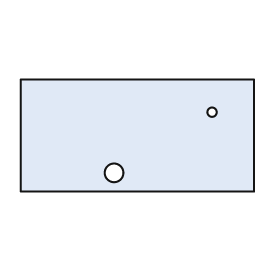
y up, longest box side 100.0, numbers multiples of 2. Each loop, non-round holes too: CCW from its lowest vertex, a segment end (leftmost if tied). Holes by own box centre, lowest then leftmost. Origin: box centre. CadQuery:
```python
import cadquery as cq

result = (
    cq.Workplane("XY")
    .moveTo(-50.0, -24.0)
    .lineTo(50.0, -24.0)
    .lineTo(50.0, 24.0)
    .lineTo(-50.0, 24.0)
    .close()
    .moveTo(-10.0, -16.0)
    .circle(4.0)
    .moveTo(32.0, 10.0)
    .circle(2.0)
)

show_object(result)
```